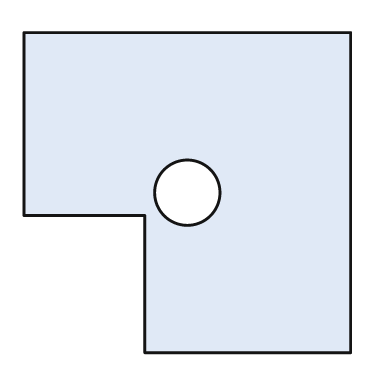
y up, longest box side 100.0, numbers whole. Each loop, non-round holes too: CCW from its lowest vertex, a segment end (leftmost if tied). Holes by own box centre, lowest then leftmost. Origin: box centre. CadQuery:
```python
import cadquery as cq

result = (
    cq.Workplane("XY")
    .moveTo(-13.0, -49.0)
    .lineTo(50.0, -49.0)
    .lineTo(50.0, 49.0)
    .lineTo(-50.0, 49.0)
    .lineTo(-50.0, -7.0)
    .lineTo(-13.0, -7.0)
    .close()
    .moveTo(0.0, 0.0)
    .circle(10.0)
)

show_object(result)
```